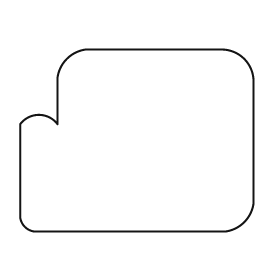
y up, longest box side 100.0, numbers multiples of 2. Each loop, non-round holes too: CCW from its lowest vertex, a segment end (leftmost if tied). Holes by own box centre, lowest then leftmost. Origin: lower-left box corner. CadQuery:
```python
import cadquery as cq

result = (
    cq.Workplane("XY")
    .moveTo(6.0, 0.0)
    .lineTo(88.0, 0.0)
    .threePointArc((96.0, 4.0), (100.0, 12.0))
    .lineTo(100.0, 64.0)
    .threePointArc((96.0, 74.0), (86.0, 78.0))
    .lineTo(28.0, 78.0)
    .threePointArc((20.0, 74.0), (16.0, 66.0))
    .lineTo(16.0, 46.0)
    .threePointArc((8.0, 50.0), (0.0, 46.0))
    .lineTo(0.0, 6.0)
    .threePointArc((2.0, 2.0), (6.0, 0.0))
    .close()
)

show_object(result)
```